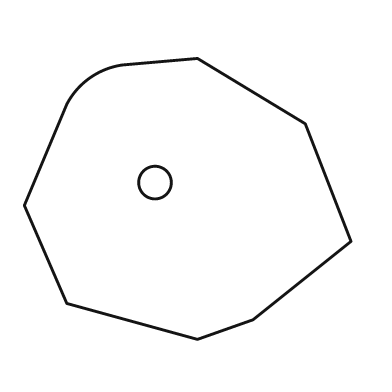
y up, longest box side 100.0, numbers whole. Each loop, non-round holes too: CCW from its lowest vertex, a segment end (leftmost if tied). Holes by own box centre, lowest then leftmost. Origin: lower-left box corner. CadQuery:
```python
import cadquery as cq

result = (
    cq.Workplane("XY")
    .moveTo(53.0, 0.0)
    .lineTo(70.0, 6.0)
    .lineTo(100.0, 30.0)
    .lineTo(86.0, 66.0)
    .lineTo(53.0, 86.0)
    .lineTo(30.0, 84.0)
    .threePointArc((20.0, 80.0), (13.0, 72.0))
    .lineTo(0.0, 41.0)
    .lineTo(13.0, 11.0)
    .close()
    .moveTo(40.0, 48.0)
    .circle(5.0)
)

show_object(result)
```